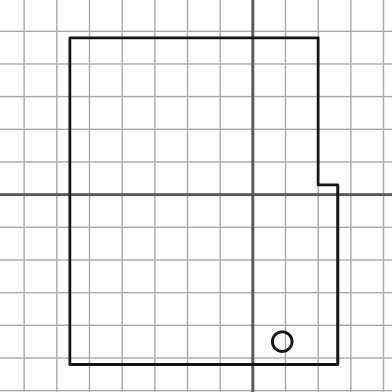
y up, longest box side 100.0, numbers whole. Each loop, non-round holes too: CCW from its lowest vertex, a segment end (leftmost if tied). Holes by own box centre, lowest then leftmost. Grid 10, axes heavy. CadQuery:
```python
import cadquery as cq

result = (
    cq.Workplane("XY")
    .moveTo(-56.0, -52.0)
    .lineTo(26.0, -52.0)
    .lineTo(26.0, 3.0)
    .lineTo(20.0, 3.0)
    .lineTo(20.0, 48.0)
    .lineTo(-56.0, 48.0)
    .close()
    .moveTo(9.0, -45.0)
    .circle(3.0)
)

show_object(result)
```